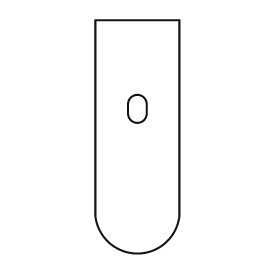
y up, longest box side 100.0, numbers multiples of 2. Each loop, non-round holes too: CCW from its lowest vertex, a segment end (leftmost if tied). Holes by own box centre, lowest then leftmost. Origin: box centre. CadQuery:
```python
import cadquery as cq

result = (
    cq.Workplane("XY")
    .moveTo(-18.0, -34.0)
    .threePointArc((0.0, -50.0), (18.0, -34.0))
    .lineTo(18.0, 50.0)
    .lineTo(-18.0, 50.0)
    .close()
    .moveTo(-4.0, 10.0)
    .threePointArc((0.0, 6.0), (4.0, 10.0))
    .lineTo(4.0, 14.0)
    .threePointArc((0.0, 18.0), (-4.0, 14.0))
    .close()
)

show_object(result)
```